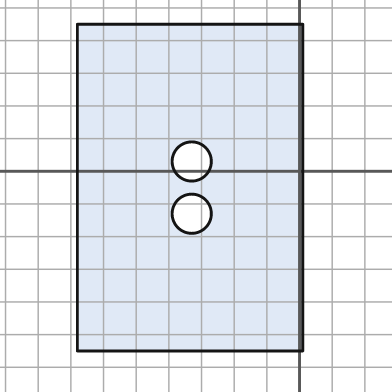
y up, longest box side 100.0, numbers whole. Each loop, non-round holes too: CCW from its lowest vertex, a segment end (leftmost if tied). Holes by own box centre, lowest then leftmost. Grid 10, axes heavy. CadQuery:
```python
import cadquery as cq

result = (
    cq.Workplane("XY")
    .moveTo(-68.0, -55.0)
    .lineTo(1.0, -55.0)
    .lineTo(1.0, 45.0)
    .lineTo(-68.0, 45.0)
    .close()
    .moveTo(-33.0, -13.0)
    .circle(6.0)
    .moveTo(-33.0, 3.0)
    .circle(6.0)
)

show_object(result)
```